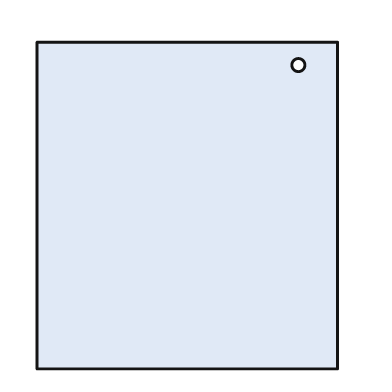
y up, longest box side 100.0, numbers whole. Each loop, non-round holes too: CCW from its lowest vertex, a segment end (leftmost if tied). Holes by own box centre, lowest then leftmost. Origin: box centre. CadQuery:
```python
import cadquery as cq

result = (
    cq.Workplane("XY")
    .moveTo(-46.0, -50.0)
    .lineTo(46.0, -50.0)
    .lineTo(46.0, 50.0)
    .lineTo(-46.0, 50.0)
    .close()
    .moveTo(34.0, 43.0)
    .circle(2.0)
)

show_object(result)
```